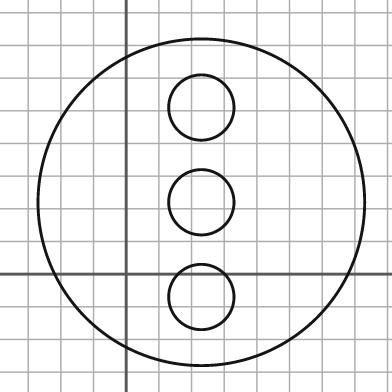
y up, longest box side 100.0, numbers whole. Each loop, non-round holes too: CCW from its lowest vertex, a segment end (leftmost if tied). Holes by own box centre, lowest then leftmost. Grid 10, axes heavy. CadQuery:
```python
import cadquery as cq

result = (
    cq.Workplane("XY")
    .moveTo(23.0, 22.0)
    .circle(50.0)
    .moveTo(23.0, -7.0)
    .circle(10.0)
    .moveTo(23.0, 22.0)
    .circle(10.0)
    .moveTo(23.0, 51.0)
    .circle(10.0)
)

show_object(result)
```